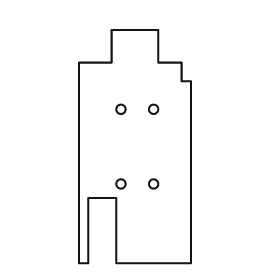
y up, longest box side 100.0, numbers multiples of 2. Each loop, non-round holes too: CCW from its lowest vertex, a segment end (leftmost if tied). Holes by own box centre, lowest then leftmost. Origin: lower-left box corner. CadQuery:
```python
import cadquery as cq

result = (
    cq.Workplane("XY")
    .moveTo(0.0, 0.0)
    .lineTo(4.0, 0.0)
    .lineTo(4.0, 28.0)
    .lineTo(16.0, 28.0)
    .lineTo(16.0, 0.0)
    .lineTo(48.0, 0.0)
    .lineTo(48.0, 78.0)
    .lineTo(44.0, 78.0)
    .lineTo(44.0, 86.0)
    .lineTo(34.0, 86.0)
    .lineTo(34.0, 100.0)
    .lineTo(14.0, 100.0)
    .lineTo(14.0, 86.0)
    .lineTo(0.0, 86.0)
    .close()
    .moveTo(18.0, 34.0)
    .circle(2.0)
    .moveTo(32.0, 34.0)
    .circle(2.0)
    .moveTo(18.0, 66.0)
    .circle(2.0)
    .moveTo(32.0, 66.0)
    .circle(2.0)
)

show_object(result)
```